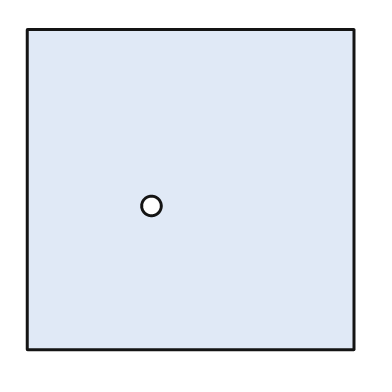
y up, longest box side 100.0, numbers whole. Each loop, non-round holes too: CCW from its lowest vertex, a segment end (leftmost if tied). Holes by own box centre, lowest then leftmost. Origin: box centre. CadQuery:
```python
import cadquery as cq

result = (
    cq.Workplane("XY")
    .moveTo(-50.0, -49.0)
    .lineTo(50.0, -49.0)
    .lineTo(50.0, 49.0)
    .lineTo(-50.0, 49.0)
    .close()
    .moveTo(-12.0, -5.0)
    .circle(3.0)
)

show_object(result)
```